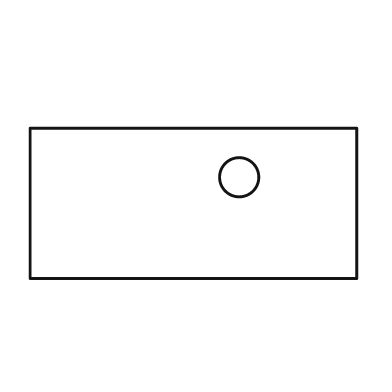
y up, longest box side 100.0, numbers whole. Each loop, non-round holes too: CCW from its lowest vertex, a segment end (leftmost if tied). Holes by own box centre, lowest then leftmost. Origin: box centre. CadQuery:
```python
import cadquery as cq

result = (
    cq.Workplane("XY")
    .moveTo(-50.0, -23.0)
    .lineTo(50.0, -23.0)
    .lineTo(50.0, 23.0)
    .lineTo(-50.0, 23.0)
    .close()
    .moveTo(14.0, 8.0)
    .circle(6.0)
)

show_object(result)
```